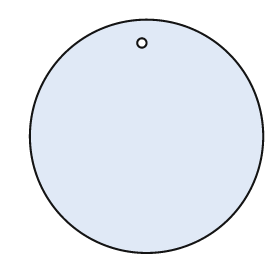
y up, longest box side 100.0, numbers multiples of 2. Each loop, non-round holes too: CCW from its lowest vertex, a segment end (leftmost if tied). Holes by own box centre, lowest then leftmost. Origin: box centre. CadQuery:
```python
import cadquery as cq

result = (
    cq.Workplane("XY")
    .moveTo(0.0, 0.0)
    .circle(50.0)
    .moveTo(-2.0, 40.0)
    .circle(2.0)
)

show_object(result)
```